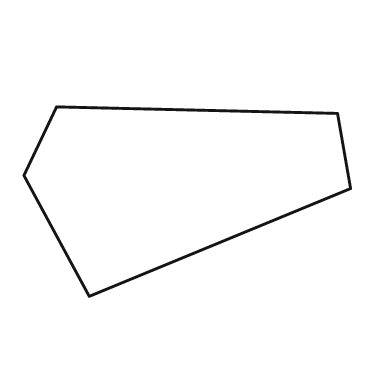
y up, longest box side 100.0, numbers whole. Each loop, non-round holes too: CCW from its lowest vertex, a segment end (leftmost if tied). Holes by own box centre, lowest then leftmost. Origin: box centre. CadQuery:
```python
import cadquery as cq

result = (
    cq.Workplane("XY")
    .moveTo(-30.0, -29.0)
    .lineTo(50.0, 4.0)
    .lineTo(46.0, 27.0)
    .lineTo(-40.0, 29.0)
    .lineTo(-50.0, 8.0)
    .close()
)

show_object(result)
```